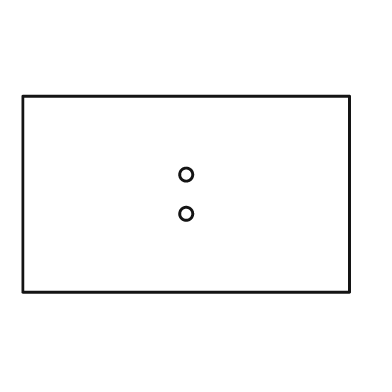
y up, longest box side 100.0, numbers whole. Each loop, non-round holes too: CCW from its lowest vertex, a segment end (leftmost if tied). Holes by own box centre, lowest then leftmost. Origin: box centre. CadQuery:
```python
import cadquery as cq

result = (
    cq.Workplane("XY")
    .moveTo(-50.0, -30.0)
    .lineTo(50.0, -30.0)
    .lineTo(50.0, 30.0)
    .lineTo(-50.0, 30.0)
    .close()
    .moveTo(0.0, -6.0)
    .circle(2.0)
    .moveTo(0.0, 6.0)
    .circle(2.0)
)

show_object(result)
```